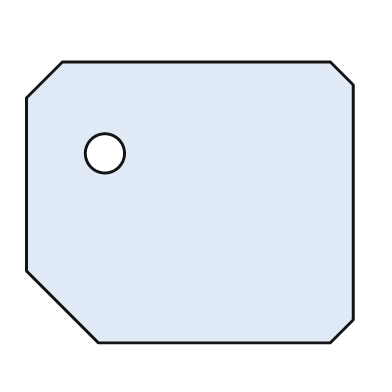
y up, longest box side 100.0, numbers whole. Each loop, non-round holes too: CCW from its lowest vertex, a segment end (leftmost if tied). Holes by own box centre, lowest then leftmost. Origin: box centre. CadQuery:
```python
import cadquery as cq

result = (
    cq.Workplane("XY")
    .moveTo(-28.0, -43.0)
    .lineTo(43.0, -43.0)
    .lineTo(50.0, -36.0)
    .lineTo(50.0, 36.0)
    .lineTo(43.0, 43.0)
    .lineTo(-39.0, 43.0)
    .lineTo(-50.0, 32.0)
    .lineTo(-50.0, -21.0)
    .close()
    .moveTo(-26.0, 15.0)
    .circle(6.0)
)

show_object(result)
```